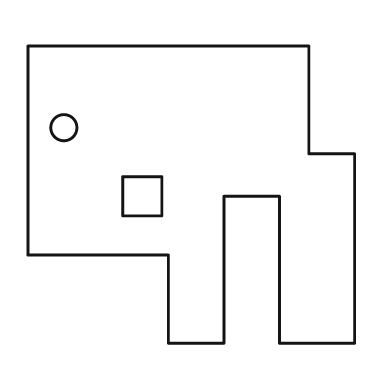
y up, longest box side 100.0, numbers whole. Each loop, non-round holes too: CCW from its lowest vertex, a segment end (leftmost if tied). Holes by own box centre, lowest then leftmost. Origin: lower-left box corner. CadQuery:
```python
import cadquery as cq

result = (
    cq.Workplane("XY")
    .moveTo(43.0, 0.0)
    .lineTo(60.0, 0.0)
    .lineTo(60.0, 45.0)
    .lineTo(77.0, 45.0)
    .lineTo(77.0, 0.0)
    .lineTo(100.0, 0.0)
    .lineTo(100.0, 58.0)
    .lineTo(86.0, 58.0)
    .lineTo(86.0, 91.0)
    .lineTo(0.0, 91.0)
    .lineTo(0.0, 27.0)
    .lineTo(43.0, 27.0)
    .close()
    .moveTo(29.0, 39.0)
    .lineTo(41.0, 39.0)
    .lineTo(41.0, 51.0)
    .lineTo(29.0, 51.0)
    .close()
    .moveTo(11.0, 66.0)
    .circle(4.0)
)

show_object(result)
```